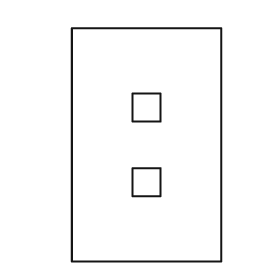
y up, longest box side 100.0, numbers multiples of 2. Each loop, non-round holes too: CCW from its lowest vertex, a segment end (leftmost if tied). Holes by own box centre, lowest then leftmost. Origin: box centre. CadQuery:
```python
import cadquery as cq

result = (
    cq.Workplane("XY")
    .moveTo(-32.0, -50.0)
    .lineTo(32.0, -50.0)
    .lineTo(32.0, 50.0)
    .lineTo(-32.0, 50.0)
    .close()
    .moveTo(-6.0, -22.0)
    .lineTo(6.0, -22.0)
    .lineTo(6.0, -10.0)
    .lineTo(-6.0, -10.0)
    .close()
    .moveTo(-6.0, 10.0)
    .lineTo(6.0, 10.0)
    .lineTo(6.0, 22.0)
    .lineTo(-6.0, 22.0)
    .close()
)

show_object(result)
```